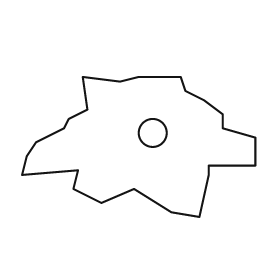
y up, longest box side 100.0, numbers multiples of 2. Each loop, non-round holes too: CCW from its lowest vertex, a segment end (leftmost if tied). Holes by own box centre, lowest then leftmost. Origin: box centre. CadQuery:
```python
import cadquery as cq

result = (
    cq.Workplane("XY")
    .moveTo(26.0, -30.0)
    .lineTo(30.0, -12.0)
    .lineTo(30.0, -8.0)
    .lineTo(50.0, -8.0)
    .lineTo(50.0, 4.0)
    .lineTo(36.0, 8.0)
    .lineTo(36.0, 14.0)
    .lineTo(28.0, 20.0)
    .lineTo(20.0, 24.0)
    .lineTo(18.0, 30.0)
    .lineTo(0.0, 30.0)
    .lineTo(-8.0, 28.0)
    .lineTo(-24.0, 30.0)
    .lineTo(-22.0, 16.0)
    .lineTo(-30.0, 12.0)
    .lineTo(-32.0, 8.0)
    .lineTo(-44.0, 2.0)
    .lineTo(-48.0, -4.0)
    .lineTo(-50.0, -12.0)
    .lineTo(-26.0, -10.0)
    .lineTo(-28.0, -18.0)
    .lineTo(-16.0, -24.0)
    .lineTo(-2.0, -18.0)
    .lineTo(14.0, -28.0)
    .close()
    .moveTo(6.0, 6.0)
    .circle(6.0)
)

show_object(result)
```